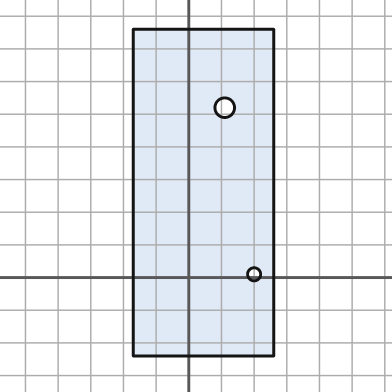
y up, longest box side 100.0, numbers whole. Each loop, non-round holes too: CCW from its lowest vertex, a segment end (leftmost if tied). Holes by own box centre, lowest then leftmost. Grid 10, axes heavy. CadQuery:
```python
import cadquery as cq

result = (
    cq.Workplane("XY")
    .moveTo(-17.0, -24.0)
    .lineTo(26.0, -24.0)
    .lineTo(26.0, 76.0)
    .lineTo(-17.0, 76.0)
    .close()
    .moveTo(20.0, 1.0)
    .circle(2.0)
    .moveTo(11.0, 52.0)
    .circle(3.0)
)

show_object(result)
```